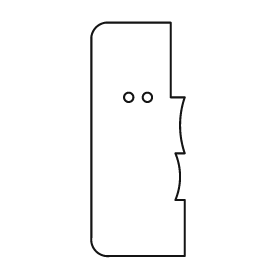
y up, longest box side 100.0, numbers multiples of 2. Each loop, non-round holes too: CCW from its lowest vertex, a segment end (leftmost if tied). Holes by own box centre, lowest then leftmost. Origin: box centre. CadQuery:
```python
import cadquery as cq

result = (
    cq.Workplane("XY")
    .moveTo(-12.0, -50.0)
    .lineTo(20.0, -50.0)
    .lineTo(20.0, -26.0)
    .lineTo(16.0, -26.0)
    .threePointArc((18.0, -16.0), (16.0, -6.0))
    .lineTo(20.0, -6.0)
    .threePointArc((18.0, 6.0), (20.0, 18.0))
    .lineTo(14.0, 18.0)
    .lineTo(14.0, 50.0)
    .lineTo(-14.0, 50.0)
    .threePointArc((-18.0, 48.0), (-20.0, 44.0))
    .lineTo(-20.0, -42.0)
    .threePointArc((-18.0, -48.0), (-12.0, -50.0))
    .close()
    .moveTo(-4.0, 18.0)
    .circle(2.0)
    .moveTo(4.0, 18.0)
    .circle(2.0)
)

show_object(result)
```